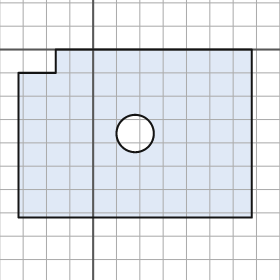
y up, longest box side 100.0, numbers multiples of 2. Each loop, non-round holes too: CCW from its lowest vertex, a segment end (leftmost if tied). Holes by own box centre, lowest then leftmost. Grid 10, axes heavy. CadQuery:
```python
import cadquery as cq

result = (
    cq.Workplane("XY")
    .moveTo(-32.0, -72.0)
    .lineTo(68.0, -72.0)
    .lineTo(68.0, 0.0)
    .lineTo(-16.0, 0.0)
    .lineTo(-16.0, -10.0)
    .lineTo(-32.0, -10.0)
    .close()
    .moveTo(18.0, -36.0)
    .circle(8.0)
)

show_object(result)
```